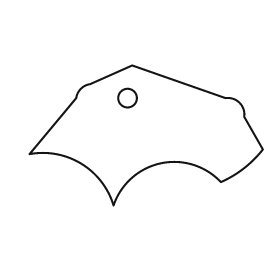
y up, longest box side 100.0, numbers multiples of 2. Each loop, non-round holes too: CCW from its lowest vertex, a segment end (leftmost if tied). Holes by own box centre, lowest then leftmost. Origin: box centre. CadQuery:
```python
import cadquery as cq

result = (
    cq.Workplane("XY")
    .moveTo(-14.0, -30.0)
    .threePointArc((6.0, -12.0), (32.0, -20.0))
    .threePointArc((42.0, -14.0), (50.0, -6.0))
    .lineTo(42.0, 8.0)
    .threePointArc((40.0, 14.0), (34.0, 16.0))
    .lineTo(-6.0, 30.0)
    .lineTo(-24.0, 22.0)
    .threePointArc((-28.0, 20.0), (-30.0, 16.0))
    .lineTo(-50.0, -8.0)
    .threePointArc((-28.0, -12.0), (-14.0, -30.0))
    .close()
    .moveTo(-8.0, 16.0)
    .circle(4.0)
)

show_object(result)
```